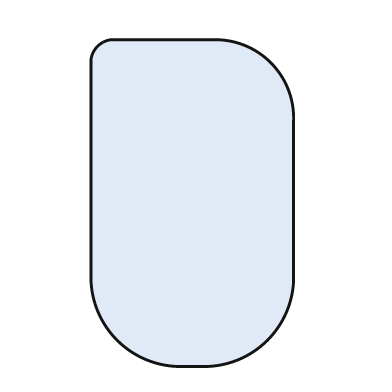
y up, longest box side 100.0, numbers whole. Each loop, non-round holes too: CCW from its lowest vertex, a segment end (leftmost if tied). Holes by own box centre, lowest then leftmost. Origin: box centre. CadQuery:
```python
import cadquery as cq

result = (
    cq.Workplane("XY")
    .moveTo(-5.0, -50.0)
    .lineTo(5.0, -50.0)
    .threePointArc((23.0, -42.0), (31.0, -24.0))
    .lineTo(31.0, 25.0)
    .threePointArc((24.0, 43.0), (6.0, 50.0))
    .lineTo(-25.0, 50.0)
    .threePointArc((-29.0, 48.0), (-31.0, 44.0))
    .lineTo(-31.0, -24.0)
    .threePointArc((-23.0, -42.0), (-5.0, -50.0))
    .close()
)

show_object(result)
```